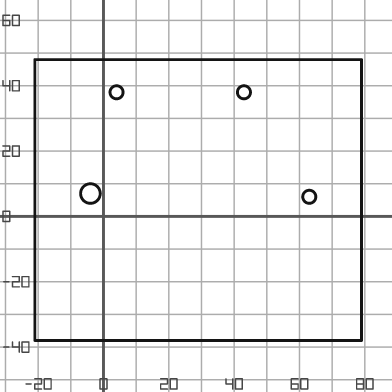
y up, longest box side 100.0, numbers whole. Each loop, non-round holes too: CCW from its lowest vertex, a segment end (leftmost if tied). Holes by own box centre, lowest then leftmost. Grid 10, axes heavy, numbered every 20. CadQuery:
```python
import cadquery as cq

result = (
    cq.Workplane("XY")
    .moveTo(-21.0, -38.0)
    .lineTo(79.0, -38.0)
    .lineTo(79.0, 48.0)
    .lineTo(-21.0, 48.0)
    .close()
    .moveTo(63.0, 6.0)
    .circle(2.0)
    .moveTo(-4.0, 7.0)
    .circle(3.0)
    .moveTo(4.0, 38.0)
    .circle(2.0)
    .moveTo(43.0, 38.0)
    .circle(2.0)
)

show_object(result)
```